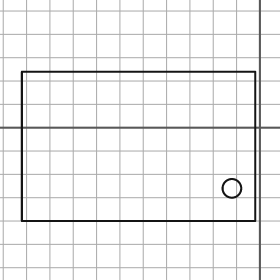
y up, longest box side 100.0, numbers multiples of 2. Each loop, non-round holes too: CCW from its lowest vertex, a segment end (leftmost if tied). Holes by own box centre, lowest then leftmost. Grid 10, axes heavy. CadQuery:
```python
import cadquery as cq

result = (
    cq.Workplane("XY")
    .moveTo(-102.0, -40.0)
    .lineTo(-2.0, -40.0)
    .lineTo(-2.0, 24.0)
    .lineTo(-102.0, 24.0)
    .close()
    .moveTo(-12.0, -26.0)
    .circle(4.0)
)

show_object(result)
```